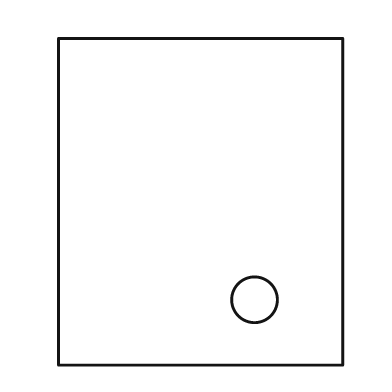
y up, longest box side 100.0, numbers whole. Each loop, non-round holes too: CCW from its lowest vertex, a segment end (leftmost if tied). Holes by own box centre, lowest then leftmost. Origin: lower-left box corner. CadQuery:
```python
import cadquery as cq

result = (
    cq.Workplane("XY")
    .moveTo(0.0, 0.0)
    .lineTo(87.0, 0.0)
    .lineTo(87.0, 100.0)
    .lineTo(0.0, 100.0)
    .close()
    .moveTo(60.0, 20.0)
    .circle(7.0)
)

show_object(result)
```